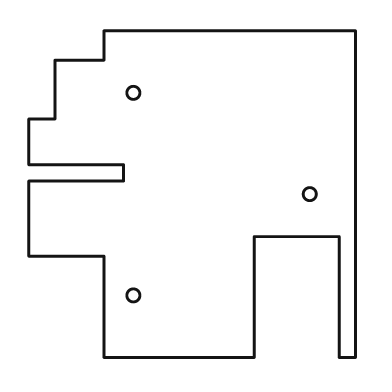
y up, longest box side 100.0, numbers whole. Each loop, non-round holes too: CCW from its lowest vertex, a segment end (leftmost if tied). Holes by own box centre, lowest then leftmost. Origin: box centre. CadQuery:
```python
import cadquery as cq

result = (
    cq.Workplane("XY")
    .moveTo(-27.0, -50.0)
    .lineTo(19.0, -50.0)
    .lineTo(19.0, -13.0)
    .lineTo(45.0, -13.0)
    .lineTo(45.0, -50.0)
    .lineTo(50.0, -50.0)
    .lineTo(50.0, 50.0)
    .lineTo(-27.0, 50.0)
    .lineTo(-27.0, 41.0)
    .lineTo(-42.0, 41.0)
    .lineTo(-42.0, 23.0)
    .lineTo(-50.0, 23.0)
    .lineTo(-50.0, 9.0)
    .lineTo(-21.0, 9.0)
    .lineTo(-21.0, 4.0)
    .lineTo(-50.0, 4.0)
    .lineTo(-50.0, -19.0)
    .lineTo(-27.0, -19.0)
    .close()
    .moveTo(-18.0, -31.0)
    .circle(2.0)
    .moveTo(36.0, 0.0)
    .circle(2.0)
    .moveTo(-18.0, 31.0)
    .circle(2.0)
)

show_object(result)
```